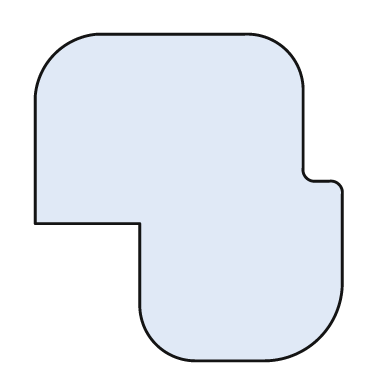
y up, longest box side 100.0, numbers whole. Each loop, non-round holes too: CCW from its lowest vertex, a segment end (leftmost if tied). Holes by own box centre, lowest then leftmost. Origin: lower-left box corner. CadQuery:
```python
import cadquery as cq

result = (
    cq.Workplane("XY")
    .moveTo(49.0, 0.0)
    .lineTo(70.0, 0.0)
    .threePointArc((87.0, 7.0), (94.0, 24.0))
    .lineTo(94.0, 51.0)
    .threePointArc((93.0, 54.0), (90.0, 55.0))
    .lineTo(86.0, 55.0)
    .threePointArc((83.0, 56.0), (82.0, 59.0))
    .lineTo(82.0, 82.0)
    .threePointArc((77.0, 95.0), (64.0, 100.0))
    .lineTo(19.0, 100.0)
    .threePointArc((6.0, 94.0), (0.0, 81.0))
    .lineTo(0.0, 42.0)
    .lineTo(32.0, 42.0)
    .lineTo(32.0, 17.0)
    .threePointArc((37.0, 5.0), (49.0, 0.0))
    .close()
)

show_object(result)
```